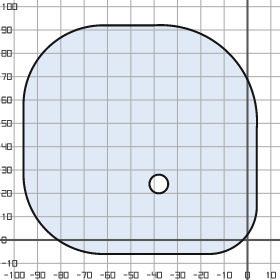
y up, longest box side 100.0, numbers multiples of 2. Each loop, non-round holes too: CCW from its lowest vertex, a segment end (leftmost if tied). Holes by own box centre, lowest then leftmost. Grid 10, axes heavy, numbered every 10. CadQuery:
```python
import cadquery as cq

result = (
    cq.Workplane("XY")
    .moveTo(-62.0, -6.0)
    .lineTo(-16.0, -6.0)
    .threePointArc((-2.0, 0.0), (4.0, 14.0))
    .lineTo(4.0, 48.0)
    .threePointArc((-8.0, 80.0), (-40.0, 92.0))
    .lineTo(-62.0, 92.0)
    .threePointArc((-86.0, 82.0), (-96.0, 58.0))
    .lineTo(-96.0, 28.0)
    .threePointArc((-86.0, 4.0), (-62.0, -6.0))
    .close()
    .moveTo(-38.0, 24.0)
    .circle(4.0)
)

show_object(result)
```